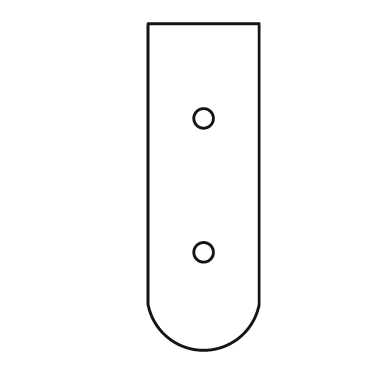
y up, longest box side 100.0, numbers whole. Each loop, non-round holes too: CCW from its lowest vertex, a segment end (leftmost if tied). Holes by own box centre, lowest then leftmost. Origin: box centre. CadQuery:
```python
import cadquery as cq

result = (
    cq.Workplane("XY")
    .moveTo(-17.0, -36.0)
    .threePointArc((0.0, -50.0), (17.0, -36.0))
    .lineTo(17.0, 50.0)
    .lineTo(-17.0, 50.0)
    .close()
    .moveTo(0.0, -20.0)
    .circle(3.0)
    .moveTo(0.0, 21.0)
    .circle(3.0)
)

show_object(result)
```